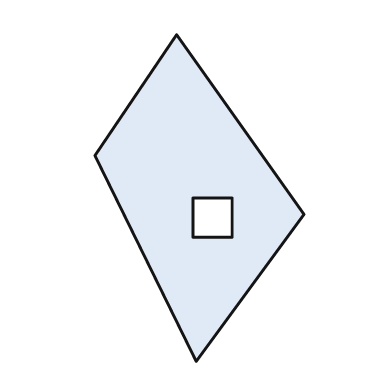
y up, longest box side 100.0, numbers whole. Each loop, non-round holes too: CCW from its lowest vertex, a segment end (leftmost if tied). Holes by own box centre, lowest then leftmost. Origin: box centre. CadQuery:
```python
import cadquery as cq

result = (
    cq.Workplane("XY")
    .moveTo(-1.0, -50.0)
    .lineTo(32.0, -5.0)
    .lineTo(-7.0, 50.0)
    .lineTo(-32.0, 13.0)
    .close()
    .moveTo(-2.0, -12.0)
    .lineTo(10.0, -12.0)
    .lineTo(10.0, 0.0)
    .lineTo(-2.0, 0.0)
    .close()
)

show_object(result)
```